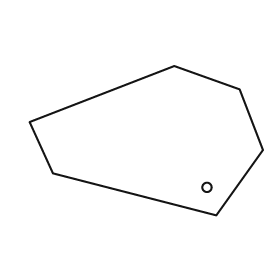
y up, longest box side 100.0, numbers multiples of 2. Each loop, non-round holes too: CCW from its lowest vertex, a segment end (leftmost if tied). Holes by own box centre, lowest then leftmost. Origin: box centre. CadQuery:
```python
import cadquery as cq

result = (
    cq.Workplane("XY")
    .moveTo(30.0, -32.0)
    .lineTo(50.0, -4.0)
    .lineTo(40.0, 22.0)
    .lineTo(12.0, 32.0)
    .lineTo(-50.0, 8.0)
    .lineTo(-40.0, -14.0)
    .close()
    .moveTo(26.0, -20.0)
    .circle(2.0)
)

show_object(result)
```